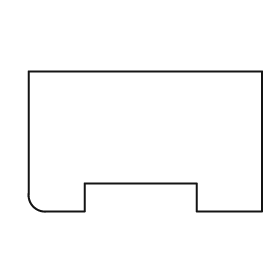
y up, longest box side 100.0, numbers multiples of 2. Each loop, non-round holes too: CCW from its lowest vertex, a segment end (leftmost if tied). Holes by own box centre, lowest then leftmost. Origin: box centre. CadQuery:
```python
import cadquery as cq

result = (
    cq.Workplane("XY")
    .moveTo(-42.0, -30.0)
    .lineTo(-26.0, -30.0)
    .lineTo(-26.0, -18.0)
    .lineTo(22.0, -18.0)
    .lineTo(22.0, -30.0)
    .lineTo(50.0, -30.0)
    .lineTo(50.0, 30.0)
    .lineTo(-50.0, 30.0)
    .lineTo(-50.0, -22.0)
    .threePointArc((-48.0, -28.0), (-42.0, -30.0))
    .close()
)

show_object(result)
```